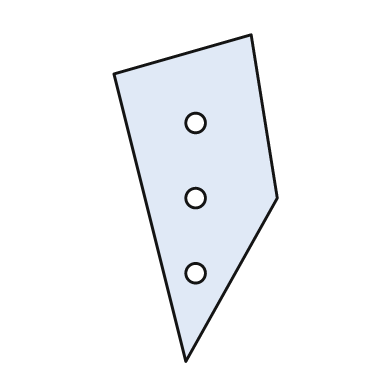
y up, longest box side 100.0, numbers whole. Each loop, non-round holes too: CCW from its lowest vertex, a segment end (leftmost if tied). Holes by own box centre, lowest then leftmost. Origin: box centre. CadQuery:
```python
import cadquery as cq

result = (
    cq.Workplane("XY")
    .moveTo(-3.0, -50.0)
    .lineTo(25.0, 0.0)
    .lineTo(17.0, 50.0)
    .lineTo(-25.0, 38.0)
    .close()
    .moveTo(0.0, -23.0)
    .circle(3.0)
    .moveTo(0.0, 0.0)
    .circle(3.0)
    .moveTo(0.0, 23.0)
    .circle(3.0)
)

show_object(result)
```